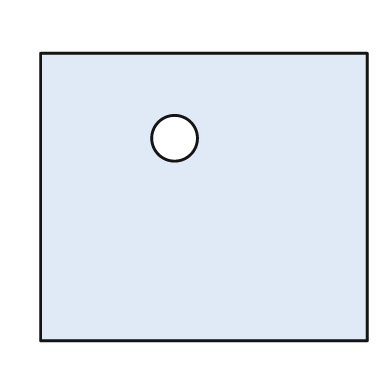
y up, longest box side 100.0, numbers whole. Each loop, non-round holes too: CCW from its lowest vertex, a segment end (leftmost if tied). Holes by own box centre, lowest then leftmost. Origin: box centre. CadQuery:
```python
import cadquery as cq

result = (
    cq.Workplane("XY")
    .moveTo(-50.0, -44.0)
    .lineTo(50.0, -44.0)
    .lineTo(50.0, 44.0)
    .lineTo(-50.0, 44.0)
    .close()
    .moveTo(-9.0, 18.0)
    .circle(7.0)
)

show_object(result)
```